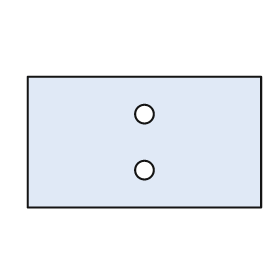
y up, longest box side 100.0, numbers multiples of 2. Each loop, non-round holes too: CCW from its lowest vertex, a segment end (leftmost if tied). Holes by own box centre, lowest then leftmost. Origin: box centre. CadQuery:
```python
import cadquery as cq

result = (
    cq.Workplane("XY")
    .moveTo(-50.0, -28.0)
    .lineTo(50.0, -28.0)
    .lineTo(50.0, 28.0)
    .lineTo(-50.0, 28.0)
    .close()
    .moveTo(0.0, -12.0)
    .circle(4.0)
    .moveTo(0.0, 12.0)
    .circle(4.0)
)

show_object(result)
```